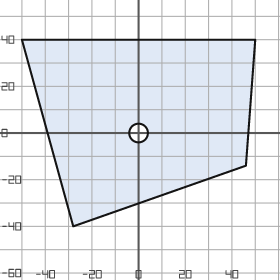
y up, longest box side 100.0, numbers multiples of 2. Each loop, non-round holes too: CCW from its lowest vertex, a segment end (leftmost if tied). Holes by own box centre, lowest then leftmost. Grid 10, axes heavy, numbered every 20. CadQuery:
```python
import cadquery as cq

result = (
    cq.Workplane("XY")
    .moveTo(-28.0, -40.0)
    .lineTo(46.0, -14.0)
    .lineTo(50.0, 40.0)
    .lineTo(-50.0, 40.0)
    .close()
    .moveTo(0.0, 0.0)
    .circle(4.0)
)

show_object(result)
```